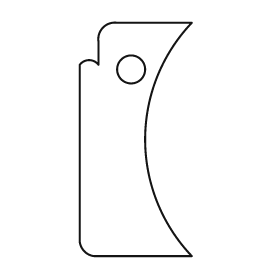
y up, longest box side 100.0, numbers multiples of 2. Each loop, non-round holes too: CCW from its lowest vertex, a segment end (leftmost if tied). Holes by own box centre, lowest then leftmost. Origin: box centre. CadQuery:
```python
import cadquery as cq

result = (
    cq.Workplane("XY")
    .moveTo(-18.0, -50.0)
    .lineTo(24.0, -50.0)
    .threePointArc((4.0, 0.0), (24.0, 50.0))
    .lineTo(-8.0, 50.0)
    .threePointArc((-14.0, 48.0), (-16.0, 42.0))
    .lineTo(-16.0, 32.0)
    .threePointArc((-20.0, 34.0), (-24.0, 32.0))
    .lineTo(-24.0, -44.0)
    .threePointArc((-22.0, -48.0), (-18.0, -50.0))
    .close()
    .moveTo(-2.0, 30.0)
    .circle(6.0)
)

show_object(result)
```